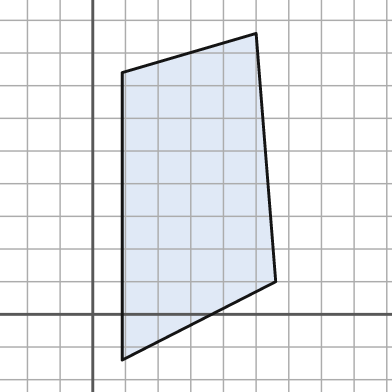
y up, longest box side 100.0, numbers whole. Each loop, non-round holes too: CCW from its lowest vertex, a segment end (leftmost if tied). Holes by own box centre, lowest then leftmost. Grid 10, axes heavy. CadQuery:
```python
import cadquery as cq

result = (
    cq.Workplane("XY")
    .moveTo(9.0, -14.0)
    .lineTo(56.0, 10.0)
    .lineTo(50.0, 86.0)
    .lineTo(9.0, 74.0)
    .close()
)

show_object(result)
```